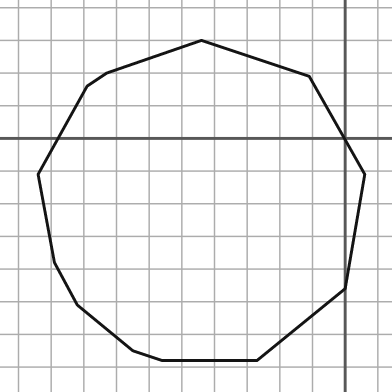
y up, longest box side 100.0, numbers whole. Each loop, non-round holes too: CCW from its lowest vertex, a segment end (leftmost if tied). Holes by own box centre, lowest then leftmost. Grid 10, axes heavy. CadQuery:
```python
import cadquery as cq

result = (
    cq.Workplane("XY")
    .moveTo(-56.0, -68.0)
    .lineTo(-27.0, -68.0)
    .lineTo(0.0, -46.0)
    .lineTo(6.0, -11.0)
    .lineTo(-11.0, 19.0)
    .lineTo(-44.0, 30.0)
    .lineTo(-73.0, 20.0)
    .lineTo(-79.0, 16.0)
    .lineTo(-94.0, -11.0)
    .lineTo(-89.0, -38.0)
    .lineTo(-82.0, -51.0)
    .lineTo(-65.0, -65.0)
    .close()
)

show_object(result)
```